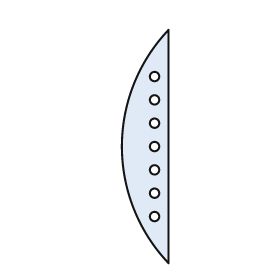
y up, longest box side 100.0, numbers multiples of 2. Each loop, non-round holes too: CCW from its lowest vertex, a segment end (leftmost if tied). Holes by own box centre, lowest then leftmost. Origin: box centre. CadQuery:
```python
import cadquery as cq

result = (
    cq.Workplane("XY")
    .moveTo(10.0, -50.0)
    .lineTo(10.0, 50.0)
    .threePointArc((-10.0, 0.0), (10.0, -50.0))
    .close()
    .moveTo(4.0, -30.0)
    .circle(2.0)
    .moveTo(4.0, -20.0)
    .circle(2.0)
    .moveTo(4.0, -10.0)
    .circle(2.0)
    .moveTo(4.0, 0.0)
    .circle(2.0)
    .moveTo(4.0, 10.0)
    .circle(2.0)
    .moveTo(4.0, 20.0)
    .circle(2.0)
    .moveTo(4.0, 30.0)
    .circle(2.0)
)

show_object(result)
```